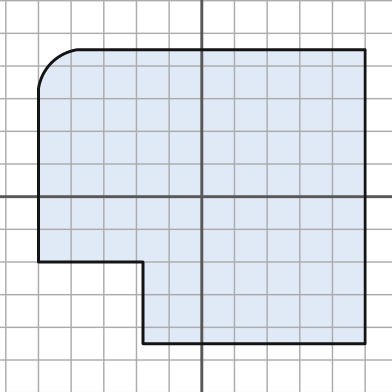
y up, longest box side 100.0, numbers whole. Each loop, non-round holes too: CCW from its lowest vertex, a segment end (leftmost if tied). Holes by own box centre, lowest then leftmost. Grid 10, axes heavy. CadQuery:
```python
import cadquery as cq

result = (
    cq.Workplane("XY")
    .moveTo(-18.0, -45.0)
    .lineTo(50.0, -45.0)
    .lineTo(50.0, 45.0)
    .lineTo(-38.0, 45.0)
    .threePointArc((-46.0, 41.0), (-50.0, 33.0))
    .lineTo(-50.0, -20.0)
    .lineTo(-18.0, -20.0)
    .close()
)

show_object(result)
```